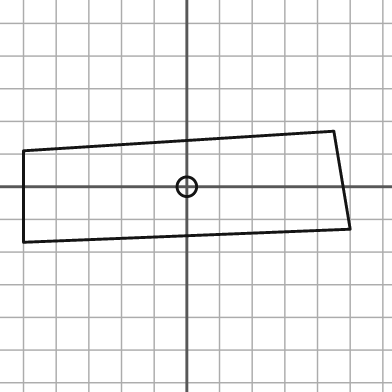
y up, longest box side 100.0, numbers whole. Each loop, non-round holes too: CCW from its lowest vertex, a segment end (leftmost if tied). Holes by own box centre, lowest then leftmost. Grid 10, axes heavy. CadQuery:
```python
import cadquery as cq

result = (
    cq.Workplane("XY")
    .moveTo(-50.0, -17.0)
    .lineTo(50.0, -13.0)
    .lineTo(45.0, 17.0)
    .lineTo(-50.0, 11.0)
    .close()
    .moveTo(0.0, 0.0)
    .circle(3.0)
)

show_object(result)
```